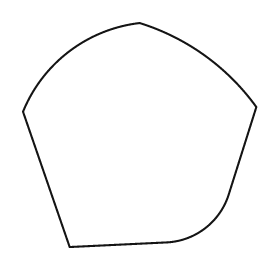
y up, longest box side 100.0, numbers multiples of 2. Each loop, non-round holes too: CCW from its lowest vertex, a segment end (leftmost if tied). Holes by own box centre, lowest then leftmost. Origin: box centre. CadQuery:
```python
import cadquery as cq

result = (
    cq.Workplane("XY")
    .moveTo(-30.0, -48.0)
    .lineTo(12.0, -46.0)
    .threePointArc((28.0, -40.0), (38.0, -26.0))
    .lineTo(50.0, 12.0)
    .threePointArc((28.0, 34.0), (0.0, 48.0))
    .threePointArc((-30.0, 36.0), (-50.0, 10.0))
    .close()
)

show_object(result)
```